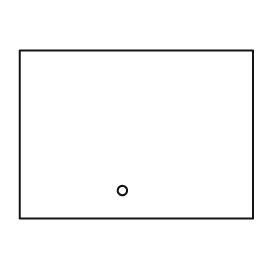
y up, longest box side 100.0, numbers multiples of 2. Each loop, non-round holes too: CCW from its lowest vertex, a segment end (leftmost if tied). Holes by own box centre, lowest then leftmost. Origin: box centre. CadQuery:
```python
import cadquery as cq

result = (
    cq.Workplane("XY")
    .moveTo(-50.0, -36.0)
    .lineTo(50.0, -36.0)
    .lineTo(50.0, 36.0)
    .lineTo(-50.0, 36.0)
    .close()
    .moveTo(-6.0, -24.0)
    .circle(2.0)
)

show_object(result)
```